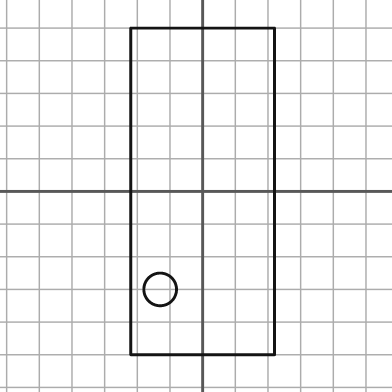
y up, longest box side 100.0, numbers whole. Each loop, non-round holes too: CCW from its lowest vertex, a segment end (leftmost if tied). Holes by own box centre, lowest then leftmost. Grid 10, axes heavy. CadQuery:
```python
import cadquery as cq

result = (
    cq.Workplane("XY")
    .moveTo(-22.0, -50.0)
    .lineTo(22.0, -50.0)
    .lineTo(22.0, 50.0)
    .lineTo(-22.0, 50.0)
    .close()
    .moveTo(-13.0, -30.0)
    .circle(5.0)
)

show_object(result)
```